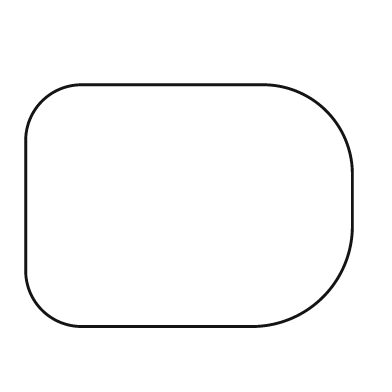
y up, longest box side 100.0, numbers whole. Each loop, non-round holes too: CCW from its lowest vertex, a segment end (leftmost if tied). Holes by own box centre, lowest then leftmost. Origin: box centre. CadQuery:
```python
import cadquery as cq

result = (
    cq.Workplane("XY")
    .moveTo(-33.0, -37.0)
    .lineTo(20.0, -37.0)
    .threePointArc((41.0, -28.0), (50.0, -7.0))
    .lineTo(50.0, 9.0)
    .threePointArc((42.0, 29.0), (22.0, 37.0))
    .lineTo(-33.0, 37.0)
    .threePointArc((-45.0, 32.0), (-50.0, 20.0))
    .lineTo(-50.0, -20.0)
    .threePointArc((-45.0, -32.0), (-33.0, -37.0))
    .close()
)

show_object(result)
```